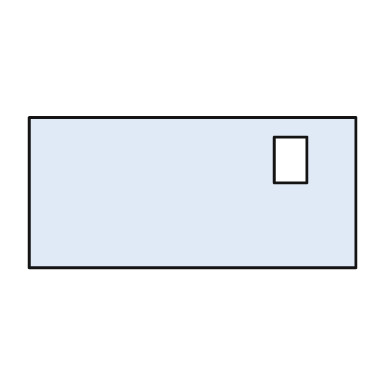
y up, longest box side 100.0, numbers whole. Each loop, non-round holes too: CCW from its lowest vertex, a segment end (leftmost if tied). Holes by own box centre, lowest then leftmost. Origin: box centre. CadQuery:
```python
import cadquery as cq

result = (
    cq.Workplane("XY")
    .moveTo(-50.0, -23.0)
    .lineTo(50.0, -23.0)
    .lineTo(50.0, 23.0)
    .lineTo(-50.0, 23.0)
    .close()
    .moveTo(25.0, 3.0)
    .lineTo(35.0, 3.0)
    .lineTo(35.0, 17.0)
    .lineTo(25.0, 17.0)
    .close()
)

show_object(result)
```